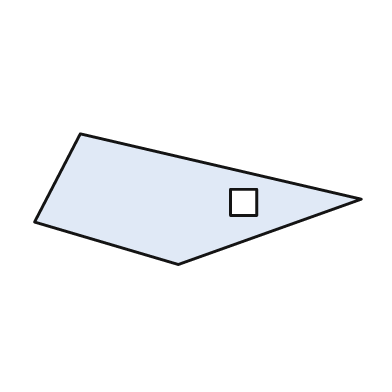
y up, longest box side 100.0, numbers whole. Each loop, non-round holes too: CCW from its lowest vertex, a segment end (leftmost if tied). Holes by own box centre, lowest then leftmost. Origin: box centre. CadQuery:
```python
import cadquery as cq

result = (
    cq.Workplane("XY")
    .moveTo(-6.0, -20.0)
    .lineTo(50.0, 0.0)
    .lineTo(-36.0, 20.0)
    .lineTo(-50.0, -7.0)
    .close()
    .moveTo(10.0, -5.0)
    .lineTo(18.0, -5.0)
    .lineTo(18.0, 3.0)
    .lineTo(10.0, 3.0)
    .close()
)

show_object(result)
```